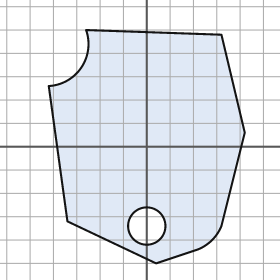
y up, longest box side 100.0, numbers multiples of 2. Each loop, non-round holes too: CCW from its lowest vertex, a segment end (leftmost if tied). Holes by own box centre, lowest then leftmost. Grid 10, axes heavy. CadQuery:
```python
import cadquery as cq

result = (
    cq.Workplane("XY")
    .moveTo(4.0, -50.0)
    .lineTo(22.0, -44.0)
    .threePointArc((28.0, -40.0), (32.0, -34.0))
    .lineTo(42.0, 6.0)
    .lineTo(32.0, 48.0)
    .lineTo(-26.0, 50.0)
    .threePointArc((-28.0, 34.0), (-42.0, 26.0))
    .lineTo(-34.0, -32.0)
    .close()
    .moveTo(0.0, -34.0)
    .circle(8.0)
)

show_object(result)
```